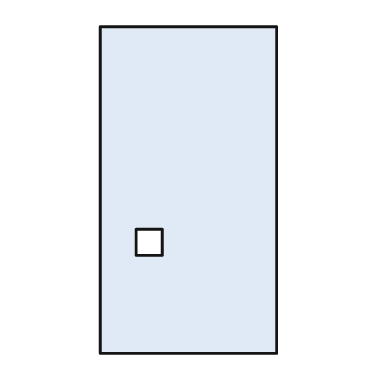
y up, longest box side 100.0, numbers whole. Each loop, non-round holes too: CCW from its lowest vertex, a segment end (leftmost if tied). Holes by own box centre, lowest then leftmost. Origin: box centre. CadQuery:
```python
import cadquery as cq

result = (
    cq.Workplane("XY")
    .moveTo(-27.0, -50.0)
    .lineTo(27.0, -50.0)
    .lineTo(27.0, 50.0)
    .lineTo(-27.0, 50.0)
    .close()
    .moveTo(-16.0, -20.0)
    .lineTo(-8.0, -20.0)
    .lineTo(-8.0, -12.0)
    .lineTo(-16.0, -12.0)
    .close()
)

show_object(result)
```